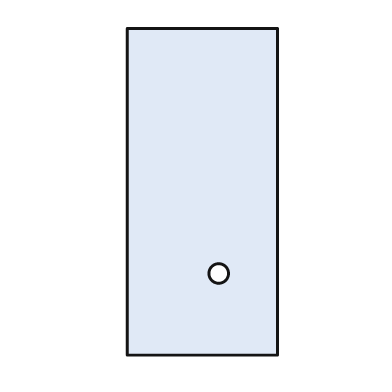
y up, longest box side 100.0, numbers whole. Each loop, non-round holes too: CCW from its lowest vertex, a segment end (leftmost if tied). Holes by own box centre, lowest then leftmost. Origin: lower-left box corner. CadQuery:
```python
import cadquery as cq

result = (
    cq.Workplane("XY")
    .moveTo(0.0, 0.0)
    .lineTo(46.0, 0.0)
    .lineTo(46.0, 100.0)
    .lineTo(0.0, 100.0)
    .close()
    .moveTo(28.0, 25.0)
    .circle(3.0)
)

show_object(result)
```